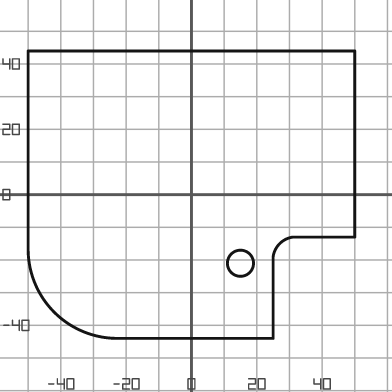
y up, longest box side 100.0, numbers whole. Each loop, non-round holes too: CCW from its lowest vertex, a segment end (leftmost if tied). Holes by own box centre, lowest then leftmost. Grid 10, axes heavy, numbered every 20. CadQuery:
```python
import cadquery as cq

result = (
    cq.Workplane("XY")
    .moveTo(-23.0, -44.0)
    .lineTo(25.0, -44.0)
    .lineTo(25.0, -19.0)
    .threePointArc((27.0, -15.0), (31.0, -13.0))
    .lineTo(50.0, -13.0)
    .lineTo(50.0, 44.0)
    .lineTo(-50.0, 44.0)
    .lineTo(-50.0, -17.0)
    .threePointArc((-42.0, -36.0), (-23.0, -44.0))
    .close()
    .moveTo(15.0, -21.0)
    .circle(4.0)
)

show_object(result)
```